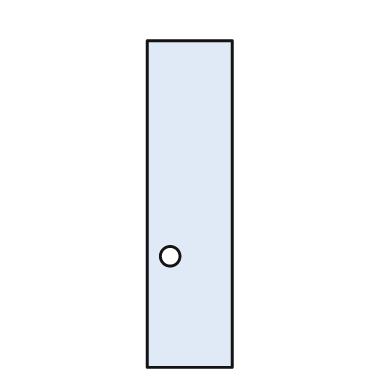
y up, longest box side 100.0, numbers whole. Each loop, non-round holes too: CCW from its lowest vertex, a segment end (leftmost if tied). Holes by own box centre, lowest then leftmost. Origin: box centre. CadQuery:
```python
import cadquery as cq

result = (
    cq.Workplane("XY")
    .moveTo(-13.0, -50.0)
    .lineTo(13.0, -50.0)
    .lineTo(13.0, 50.0)
    .lineTo(-13.0, 50.0)
    .close()
    .moveTo(-6.0, -16.0)
    .circle(3.0)
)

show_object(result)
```